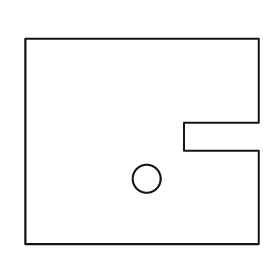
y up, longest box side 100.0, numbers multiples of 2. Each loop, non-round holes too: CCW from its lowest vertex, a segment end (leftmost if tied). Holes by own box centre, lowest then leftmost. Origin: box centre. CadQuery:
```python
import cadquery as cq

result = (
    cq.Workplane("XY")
    .moveTo(-50.0, -44.0)
    .lineTo(50.0, -44.0)
    .lineTo(50.0, -4.0)
    .lineTo(18.0, -4.0)
    .lineTo(18.0, 8.0)
    .lineTo(50.0, 8.0)
    .lineTo(50.0, 44.0)
    .lineTo(-50.0, 44.0)
    .close()
    .moveTo(2.0, -16.0)
    .circle(6.0)
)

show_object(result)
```